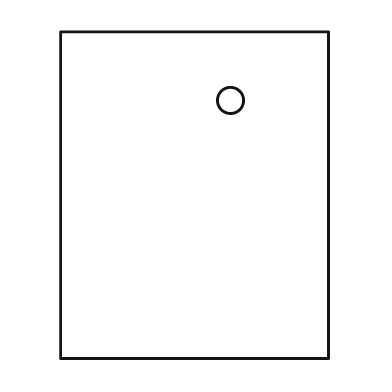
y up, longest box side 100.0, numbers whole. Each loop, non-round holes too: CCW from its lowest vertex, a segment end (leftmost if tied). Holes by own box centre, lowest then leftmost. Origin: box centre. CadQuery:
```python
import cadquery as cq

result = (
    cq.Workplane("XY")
    .moveTo(-41.0, -50.0)
    .lineTo(41.0, -50.0)
    .lineTo(41.0, 50.0)
    .lineTo(-41.0, 50.0)
    .close()
    .moveTo(11.0, 29.0)
    .circle(4.0)
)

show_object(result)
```